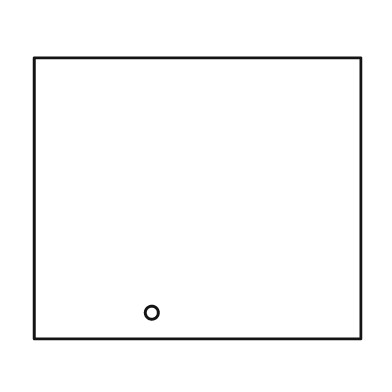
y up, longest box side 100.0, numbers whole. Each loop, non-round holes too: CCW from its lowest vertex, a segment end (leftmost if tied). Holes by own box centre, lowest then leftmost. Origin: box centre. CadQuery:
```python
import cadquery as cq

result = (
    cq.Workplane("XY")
    .moveTo(-50.0, -43.0)
    .lineTo(50.0, -43.0)
    .lineTo(50.0, 43.0)
    .lineTo(-50.0, 43.0)
    .close()
    .moveTo(-14.0, -35.0)
    .circle(2.0)
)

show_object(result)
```